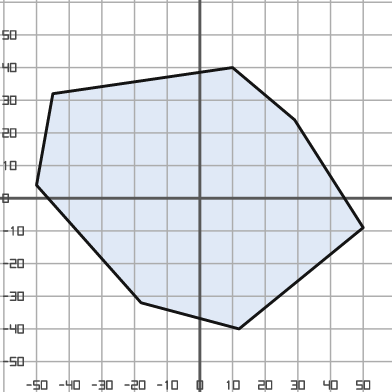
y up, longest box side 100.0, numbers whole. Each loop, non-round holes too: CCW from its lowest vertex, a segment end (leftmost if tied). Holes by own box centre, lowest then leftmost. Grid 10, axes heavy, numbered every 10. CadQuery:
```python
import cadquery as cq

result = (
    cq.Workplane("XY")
    .moveTo(12.0, -40.0)
    .lineTo(50.0, -9.0)
    .lineTo(29.0, 24.0)
    .lineTo(10.0, 40.0)
    .lineTo(-45.0, 32.0)
    .lineTo(-50.0, 4.0)
    .lineTo(-18.0, -32.0)
    .close()
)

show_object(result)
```